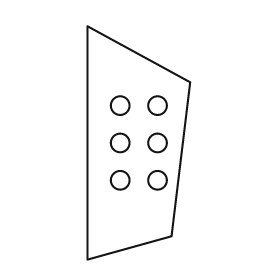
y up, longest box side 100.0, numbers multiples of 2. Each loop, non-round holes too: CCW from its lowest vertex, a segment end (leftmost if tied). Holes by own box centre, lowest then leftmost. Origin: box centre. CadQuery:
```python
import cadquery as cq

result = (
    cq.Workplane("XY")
    .moveTo(-22.0, -50.0)
    .lineTo(14.0, -40.0)
    .lineTo(22.0, 26.0)
    .lineTo(-22.0, 50.0)
    .close()
    .moveTo(-8.0, -16.0)
    .circle(4.0)
    .moveTo(8.0, -16.0)
    .circle(4.0)
    .moveTo(-8.0, 0.0)
    .circle(4.0)
    .moveTo(8.0, 0.0)
    .circle(4.0)
    .moveTo(-8.0, 16.0)
    .circle(4.0)
    .moveTo(8.0, 16.0)
    .circle(4.0)
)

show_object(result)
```